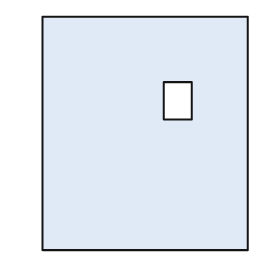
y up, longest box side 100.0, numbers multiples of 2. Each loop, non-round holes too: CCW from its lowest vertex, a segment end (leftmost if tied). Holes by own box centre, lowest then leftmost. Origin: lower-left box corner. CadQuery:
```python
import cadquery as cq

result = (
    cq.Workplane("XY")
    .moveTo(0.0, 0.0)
    .lineTo(88.0, 0.0)
    .lineTo(88.0, 100.0)
    .lineTo(0.0, 100.0)
    .close()
    .moveTo(52.0, 56.0)
    .lineTo(64.0, 56.0)
    .lineTo(64.0, 72.0)
    .lineTo(52.0, 72.0)
    .close()
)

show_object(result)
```